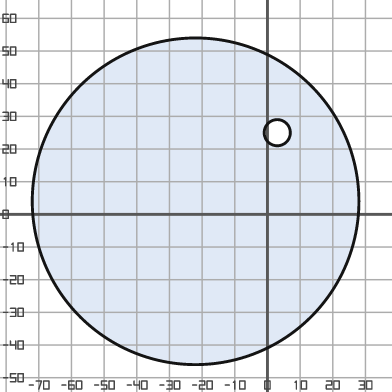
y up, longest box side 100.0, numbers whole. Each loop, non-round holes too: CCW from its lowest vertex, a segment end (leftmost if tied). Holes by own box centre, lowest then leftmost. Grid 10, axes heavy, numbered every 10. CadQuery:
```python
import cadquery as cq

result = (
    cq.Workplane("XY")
    .moveTo(-22.0, 4.0)
    .circle(50.0)
    .moveTo(3.0, 25.0)
    .circle(4.0)
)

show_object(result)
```